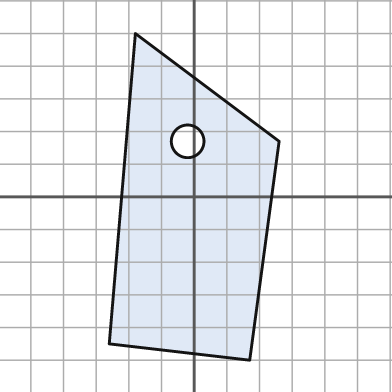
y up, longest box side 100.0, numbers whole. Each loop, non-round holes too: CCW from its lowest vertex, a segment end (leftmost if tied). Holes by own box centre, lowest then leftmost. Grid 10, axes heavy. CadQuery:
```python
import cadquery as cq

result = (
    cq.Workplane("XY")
    .moveTo(17.0, -50.0)
    .lineTo(26.0, 17.0)
    .lineTo(-18.0, 50.0)
    .lineTo(-26.0, -45.0)
    .close()
    .moveTo(-2.0, 17.0)
    .circle(5.0)
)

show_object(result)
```